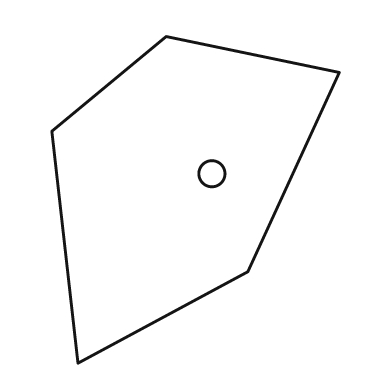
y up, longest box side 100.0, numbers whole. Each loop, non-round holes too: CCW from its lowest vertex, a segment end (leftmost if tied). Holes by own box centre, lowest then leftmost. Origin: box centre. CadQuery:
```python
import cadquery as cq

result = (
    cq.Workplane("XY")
    .moveTo(-36.0, -50.0)
    .lineTo(16.0, -22.0)
    .lineTo(44.0, 39.0)
    .lineTo(-9.0, 50.0)
    .lineTo(-44.0, 21.0)
    .close()
    .moveTo(5.0, 8.0)
    .circle(4.0)
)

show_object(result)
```